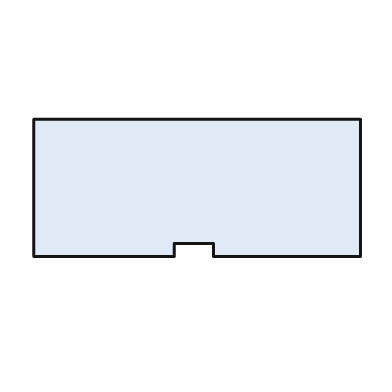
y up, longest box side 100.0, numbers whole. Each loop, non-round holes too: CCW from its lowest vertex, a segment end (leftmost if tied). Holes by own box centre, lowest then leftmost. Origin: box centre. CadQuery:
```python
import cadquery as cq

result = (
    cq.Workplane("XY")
    .moveTo(-50.0, -21.0)
    .lineTo(-7.0, -21.0)
    .lineTo(-7.0, -17.0)
    .lineTo(5.0, -17.0)
    .lineTo(5.0, -21.0)
    .lineTo(50.0, -21.0)
    .lineTo(50.0, 21.0)
    .lineTo(-50.0, 21.0)
    .close()
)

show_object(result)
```